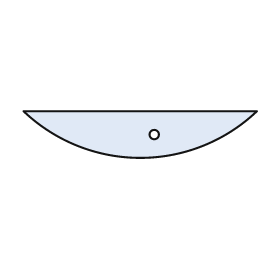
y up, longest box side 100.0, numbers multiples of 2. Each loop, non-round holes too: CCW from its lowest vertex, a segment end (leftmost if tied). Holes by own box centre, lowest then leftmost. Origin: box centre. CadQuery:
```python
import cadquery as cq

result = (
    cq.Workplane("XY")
    .moveTo(-50.0, 10.0)
    .threePointArc((0.0, -10.0), (50.0, 10.0))
    .close()
    .moveTo(6.0, 0.0)
    .circle(2.0)
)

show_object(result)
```